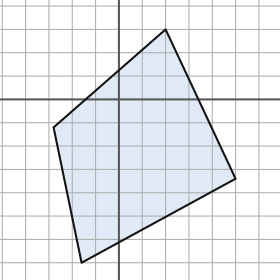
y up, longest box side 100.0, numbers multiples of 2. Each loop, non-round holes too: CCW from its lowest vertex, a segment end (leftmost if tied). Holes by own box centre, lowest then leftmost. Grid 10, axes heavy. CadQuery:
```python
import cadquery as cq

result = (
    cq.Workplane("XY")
    .moveTo(-16.0, -70.0)
    .lineTo(50.0, -34.0)
    .lineTo(20.0, 30.0)
    .lineTo(-28.0, -12.0)
    .close()
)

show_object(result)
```